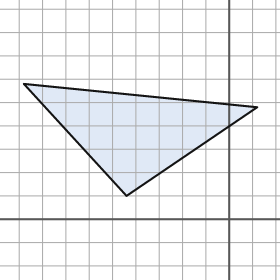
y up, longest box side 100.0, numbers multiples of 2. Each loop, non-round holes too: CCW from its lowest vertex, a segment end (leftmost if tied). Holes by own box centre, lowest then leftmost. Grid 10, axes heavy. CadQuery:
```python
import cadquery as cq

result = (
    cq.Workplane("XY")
    .moveTo(-44.0, 10.0)
    .lineTo(12.0, 48.0)
    .lineTo(-88.0, 58.0)
    .close()
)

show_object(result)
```